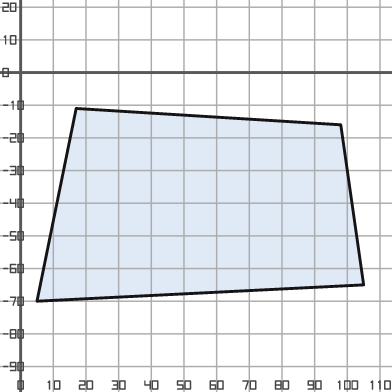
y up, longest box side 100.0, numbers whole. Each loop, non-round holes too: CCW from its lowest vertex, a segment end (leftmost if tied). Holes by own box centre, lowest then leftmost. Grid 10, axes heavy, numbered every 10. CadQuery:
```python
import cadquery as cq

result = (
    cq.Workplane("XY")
    .moveTo(5.0, -70.0)
    .lineTo(105.0, -65.0)
    .lineTo(98.0, -16.0)
    .lineTo(17.0, -11.0)
    .close()
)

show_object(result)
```